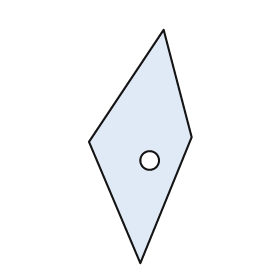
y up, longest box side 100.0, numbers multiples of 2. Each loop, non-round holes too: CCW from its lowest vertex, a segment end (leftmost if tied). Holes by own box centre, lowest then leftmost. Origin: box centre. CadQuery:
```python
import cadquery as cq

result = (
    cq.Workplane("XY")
    .moveTo(0.0, -50.0)
    .lineTo(22.0, 4.0)
    .lineTo(10.0, 50.0)
    .lineTo(-22.0, 2.0)
    .close()
    .moveTo(4.0, -6.0)
    .circle(4.0)
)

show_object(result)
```